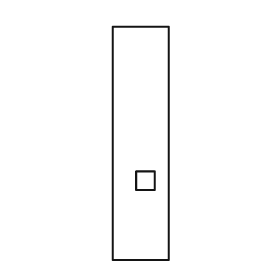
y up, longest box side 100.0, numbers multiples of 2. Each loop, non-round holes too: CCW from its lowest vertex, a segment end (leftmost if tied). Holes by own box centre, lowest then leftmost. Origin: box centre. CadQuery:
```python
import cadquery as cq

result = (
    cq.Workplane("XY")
    .moveTo(-12.0, -50.0)
    .lineTo(12.0, -50.0)
    .lineTo(12.0, 50.0)
    .lineTo(-12.0, 50.0)
    .close()
    .moveTo(-2.0, -20.0)
    .lineTo(6.0, -20.0)
    .lineTo(6.0, -12.0)
    .lineTo(-2.0, -12.0)
    .close()
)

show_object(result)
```